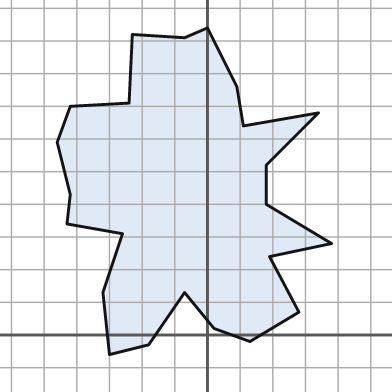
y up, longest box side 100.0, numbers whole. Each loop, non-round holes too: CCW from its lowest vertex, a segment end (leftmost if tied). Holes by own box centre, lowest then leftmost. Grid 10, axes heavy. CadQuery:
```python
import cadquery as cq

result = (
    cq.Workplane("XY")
    .moveTo(-30.0, -6.0)
    .lineTo(-18.0, -3.0)
    .lineTo(-7.0, 13.0)
    .lineTo(2.0, 2.0)
    .lineTo(13.0, -2.0)
    .lineTo(28.0, 7.0)
    .lineTo(19.0, 24.0)
    .lineTo(38.0, 28.0)
    .lineTo(18.0, 40.0)
    .lineTo(18.0, 52.0)
    .lineTo(34.0, 68.0)
    .lineTo(11.0, 64.0)
    .lineTo(9.0, 76.0)
    .lineTo(0.0, 94.0)
    .lineTo(-7.0, 91.0)
    .lineTo(-23.0, 92.0)
    .lineTo(-24.0, 71.0)
    .lineTo(-42.0, 70.0)
    .lineTo(-46.0, 59.0)
    .lineTo(-42.0, 43.0)
    .lineTo(-43.0, 34.0)
    .lineTo(-26.0, 31.0)
    .lineTo(-32.0, 13.0)
    .close()
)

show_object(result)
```